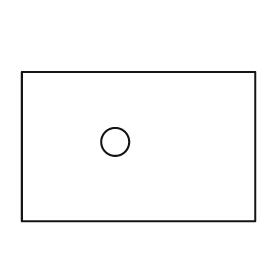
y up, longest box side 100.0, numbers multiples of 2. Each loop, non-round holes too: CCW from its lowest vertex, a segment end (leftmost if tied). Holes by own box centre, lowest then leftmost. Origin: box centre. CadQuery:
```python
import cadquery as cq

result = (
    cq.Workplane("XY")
    .moveTo(-50.0, -32.0)
    .lineTo(50.0, -32.0)
    .lineTo(50.0, 32.0)
    .lineTo(-50.0, 32.0)
    .close()
    .moveTo(-10.0, 2.0)
    .circle(6.0)
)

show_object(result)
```